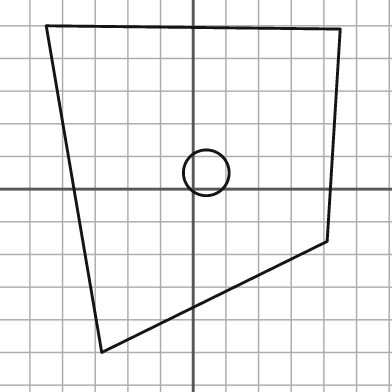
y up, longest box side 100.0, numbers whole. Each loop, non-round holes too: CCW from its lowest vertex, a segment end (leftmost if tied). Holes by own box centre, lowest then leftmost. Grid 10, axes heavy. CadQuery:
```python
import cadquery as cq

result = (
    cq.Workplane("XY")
    .moveTo(-28.0, -50.0)
    .lineTo(41.0, -16.0)
    .lineTo(45.0, 49.0)
    .lineTo(-45.0, 50.0)
    .close()
    .moveTo(4.0, 5.0)
    .circle(7.0)
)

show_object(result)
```